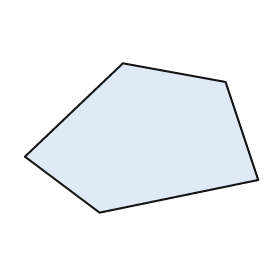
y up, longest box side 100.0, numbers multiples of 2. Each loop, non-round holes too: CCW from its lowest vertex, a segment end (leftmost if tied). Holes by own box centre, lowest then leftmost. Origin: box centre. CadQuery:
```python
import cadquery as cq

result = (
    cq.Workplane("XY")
    .moveTo(-18.0, -32.0)
    .lineTo(50.0, -18.0)
    .lineTo(36.0, 24.0)
    .lineTo(-8.0, 32.0)
    .lineTo(-50.0, -8.0)
    .close()
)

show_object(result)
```